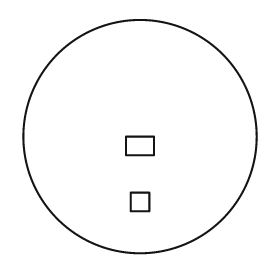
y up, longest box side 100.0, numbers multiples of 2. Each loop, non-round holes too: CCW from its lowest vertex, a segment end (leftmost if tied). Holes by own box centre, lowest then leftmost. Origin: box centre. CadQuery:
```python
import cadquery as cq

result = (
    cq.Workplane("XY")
    .moveTo(0.0, 0.0)
    .circle(50.0)
    .moveTo(-4.0, -32.0)
    .lineTo(4.0, -32.0)
    .lineTo(4.0, -24.0)
    .lineTo(-4.0, -24.0)
    .close()
    .moveTo(-6.0, -8.0)
    .lineTo(6.0, -8.0)
    .lineTo(6.0, 0.0)
    .lineTo(-6.0, 0.0)
    .close()
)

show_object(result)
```